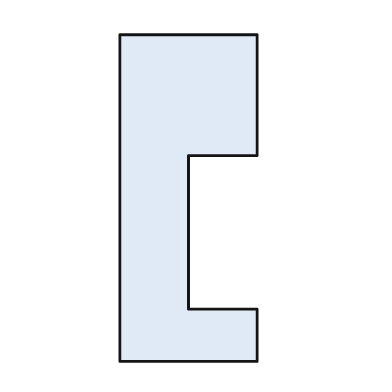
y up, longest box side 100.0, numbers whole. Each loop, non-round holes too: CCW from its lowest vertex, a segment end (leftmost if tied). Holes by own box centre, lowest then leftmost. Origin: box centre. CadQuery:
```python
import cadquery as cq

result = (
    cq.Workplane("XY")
    .moveTo(-21.0, -50.0)
    .lineTo(21.0, -50.0)
    .lineTo(21.0, -34.0)
    .lineTo(0.0, -34.0)
    .lineTo(0.0, 13.0)
    .lineTo(21.0, 13.0)
    .lineTo(21.0, 50.0)
    .lineTo(-21.0, 50.0)
    .close()
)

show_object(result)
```